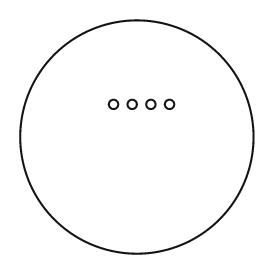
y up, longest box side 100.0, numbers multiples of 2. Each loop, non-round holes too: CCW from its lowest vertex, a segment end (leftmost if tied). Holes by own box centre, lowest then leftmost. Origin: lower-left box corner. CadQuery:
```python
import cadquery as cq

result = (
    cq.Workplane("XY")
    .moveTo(50.0, 50.0)
    .circle(50.0)
    .moveTo(40.0, 64.0)
    .circle(2.0)
    .moveTo(48.0, 64.0)
    .circle(2.0)
    .moveTo(56.0, 64.0)
    .circle(2.0)
    .moveTo(64.0, 64.0)
    .circle(2.0)
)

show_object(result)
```